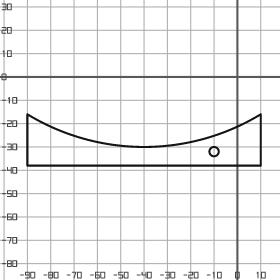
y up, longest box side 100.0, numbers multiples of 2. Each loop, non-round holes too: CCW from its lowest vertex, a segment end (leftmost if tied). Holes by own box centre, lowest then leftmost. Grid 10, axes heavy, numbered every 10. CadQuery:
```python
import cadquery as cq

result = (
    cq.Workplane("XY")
    .moveTo(-90.0, -38.0)
    .lineTo(10.0, -38.0)
    .lineTo(10.0, -16.0)
    .threePointArc((-40.0, -30.0), (-90.0, -16.0))
    .close()
    .moveTo(-10.0, -32.0)
    .circle(2.0)
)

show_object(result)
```